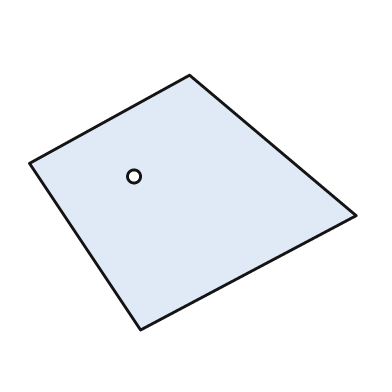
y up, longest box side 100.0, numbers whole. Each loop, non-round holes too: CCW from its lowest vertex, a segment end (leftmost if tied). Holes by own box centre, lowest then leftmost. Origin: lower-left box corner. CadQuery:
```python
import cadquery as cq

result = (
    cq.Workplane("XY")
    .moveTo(34.0, 0.0)
    .lineTo(100.0, 35.0)
    .lineTo(49.0, 78.0)
    .lineTo(0.0, 51.0)
    .close()
    .moveTo(32.0, 47.0)
    .circle(2.0)
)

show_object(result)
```